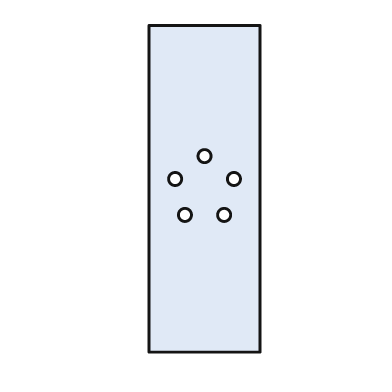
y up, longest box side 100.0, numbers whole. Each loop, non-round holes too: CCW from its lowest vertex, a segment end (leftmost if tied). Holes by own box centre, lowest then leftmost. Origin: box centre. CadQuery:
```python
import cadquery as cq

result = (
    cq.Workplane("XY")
    .moveTo(-17.0, -50.0)
    .lineTo(17.0, -50.0)
    .lineTo(17.0, 50.0)
    .lineTo(-17.0, 50.0)
    .close()
    .moveTo(-6.0, -8.0)
    .circle(2.0)
    .moveTo(6.0, -8.0)
    .circle(2.0)
    .moveTo(-9.0, 3.0)
    .circle(2.0)
    .moveTo(9.0, 3.0)
    .circle(2.0)
    .moveTo(0.0, 10.0)
    .circle(2.0)
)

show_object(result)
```